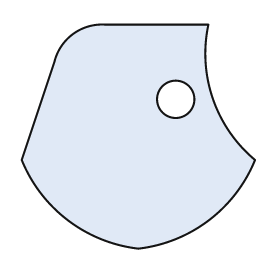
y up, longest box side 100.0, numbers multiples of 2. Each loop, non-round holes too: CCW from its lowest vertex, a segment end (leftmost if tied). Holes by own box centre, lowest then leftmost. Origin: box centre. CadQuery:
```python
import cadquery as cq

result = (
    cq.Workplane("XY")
    .moveTo(0.0, -48.0)
    .threePointArc((30.0, -36.0), (50.0, -10.0))
    .threePointArc((32.0, 16.0), (30.0, 48.0))
    .lineTo(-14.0, 48.0)
    .threePointArc((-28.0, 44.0), (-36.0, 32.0))
    .lineTo(-50.0, -10.0)
    .threePointArc((-30.0, -36.0), (0.0, -48.0))
    .close()
    .moveTo(16.0, 16.0)
    .circle(8.0)
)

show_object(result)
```